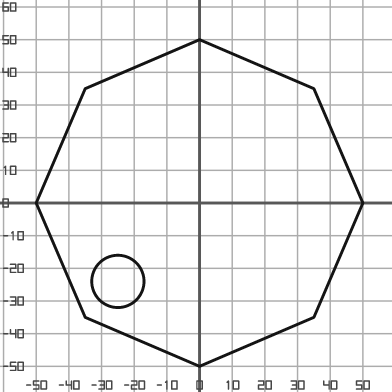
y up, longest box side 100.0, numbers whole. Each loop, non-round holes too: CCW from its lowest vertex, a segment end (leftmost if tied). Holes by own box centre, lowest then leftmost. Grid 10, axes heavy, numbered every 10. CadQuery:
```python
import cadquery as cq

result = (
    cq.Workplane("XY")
    .moveTo(0.0, -50.0)
    .lineTo(35.0, -35.0)
    .lineTo(50.0, 0.0)
    .lineTo(35.0, 35.0)
    .lineTo(0.0, 50.0)
    .lineTo(-35.0, 35.0)
    .lineTo(-50.0, 0.0)
    .lineTo(-35.0, -35.0)
    .close()
    .moveTo(-25.0, -24.0)
    .circle(8.0)
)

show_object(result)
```